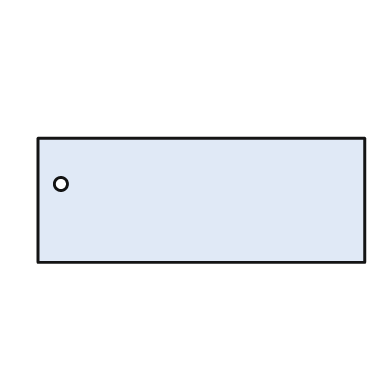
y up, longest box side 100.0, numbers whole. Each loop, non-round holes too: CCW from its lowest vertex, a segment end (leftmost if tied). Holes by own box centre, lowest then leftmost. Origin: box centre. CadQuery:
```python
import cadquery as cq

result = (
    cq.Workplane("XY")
    .moveTo(-50.0, -19.0)
    .lineTo(50.0, -19.0)
    .lineTo(50.0, 19.0)
    .lineTo(-50.0, 19.0)
    .close()
    .moveTo(-43.0, 5.0)
    .circle(2.0)
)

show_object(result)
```